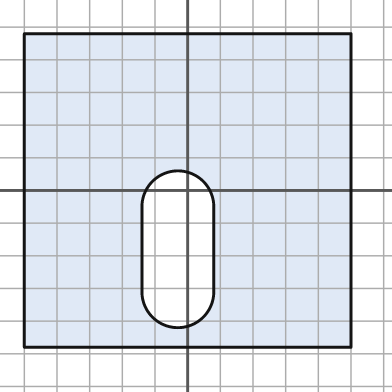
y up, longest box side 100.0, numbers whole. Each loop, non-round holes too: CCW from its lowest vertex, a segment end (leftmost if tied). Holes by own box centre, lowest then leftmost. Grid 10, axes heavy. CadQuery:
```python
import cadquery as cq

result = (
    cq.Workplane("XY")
    .moveTo(-50.0, -48.0)
    .lineTo(50.0, -48.0)
    .lineTo(50.0, 48.0)
    .lineTo(-50.0, 48.0)
    .close()
    .moveTo(-14.0, -31.0)
    .threePointArc((-3.0, -42.0), (8.0, -31.0))
    .lineTo(8.0, -5.0)
    .threePointArc((-3.0, 6.0), (-14.0, -5.0))
    .close()
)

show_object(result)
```